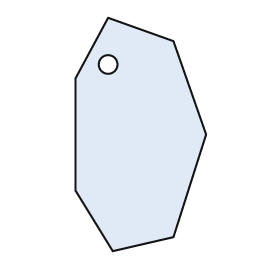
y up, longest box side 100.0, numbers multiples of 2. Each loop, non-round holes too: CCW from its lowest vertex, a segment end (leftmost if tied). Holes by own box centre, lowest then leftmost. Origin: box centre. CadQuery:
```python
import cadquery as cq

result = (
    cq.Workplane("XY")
    .moveTo(-12.0, -50.0)
    .lineTo(14.0, -44.0)
    .lineTo(28.0, 0.0)
    .lineTo(14.0, 40.0)
    .lineTo(-14.0, 50.0)
    .lineTo(-28.0, 24.0)
    .lineTo(-28.0, -24.0)
    .close()
    .moveTo(-14.0, 30.0)
    .circle(4.0)
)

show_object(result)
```